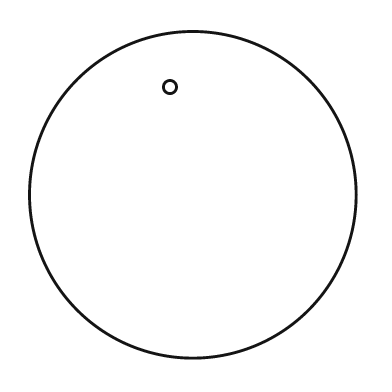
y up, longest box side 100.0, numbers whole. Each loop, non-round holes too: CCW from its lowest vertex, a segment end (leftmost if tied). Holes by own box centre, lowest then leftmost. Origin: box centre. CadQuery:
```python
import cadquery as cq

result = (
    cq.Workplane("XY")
    .moveTo(0.0, 0.0)
    .circle(50.0)
    .moveTo(-7.0, 33.0)
    .circle(2.0)
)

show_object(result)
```